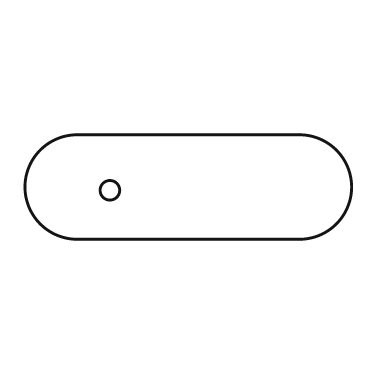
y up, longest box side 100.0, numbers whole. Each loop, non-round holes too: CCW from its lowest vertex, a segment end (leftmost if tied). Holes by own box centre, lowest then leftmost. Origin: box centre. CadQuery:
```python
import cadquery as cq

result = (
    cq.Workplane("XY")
    .moveTo(-34.0, -16.0)
    .lineTo(34.0, -16.0)
    .threePointArc((50.0, 0.0), (34.0, 16.0))
    .lineTo(-34.0, 16.0)
    .threePointArc((-50.0, 0.0), (-34.0, -16.0))
    .close()
    .moveTo(-24.0, -1.0)
    .circle(3.0)
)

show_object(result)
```